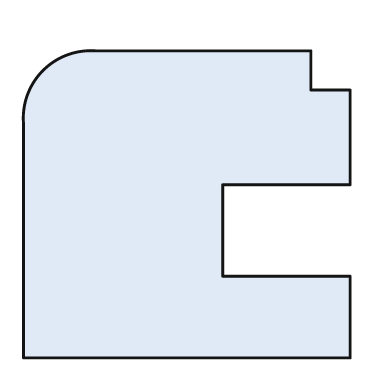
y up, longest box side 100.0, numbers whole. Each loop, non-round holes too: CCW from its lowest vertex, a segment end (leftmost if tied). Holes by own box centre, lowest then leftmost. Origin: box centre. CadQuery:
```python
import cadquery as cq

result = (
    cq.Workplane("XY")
    .moveTo(-50.0, -47.0)
    .lineTo(50.0, -47.0)
    .lineTo(50.0, -22.0)
    .lineTo(11.0, -22.0)
    .lineTo(11.0, 6.0)
    .lineTo(50.0, 6.0)
    .lineTo(50.0, 35.0)
    .lineTo(38.0, 35.0)
    .lineTo(38.0, 47.0)
    .lineTo(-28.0, 47.0)
    .threePointArc((-44.0, 41.0), (-50.0, 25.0))
    .close()
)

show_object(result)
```